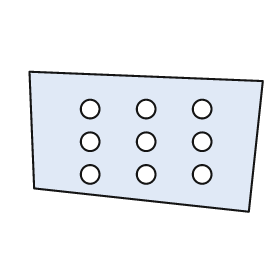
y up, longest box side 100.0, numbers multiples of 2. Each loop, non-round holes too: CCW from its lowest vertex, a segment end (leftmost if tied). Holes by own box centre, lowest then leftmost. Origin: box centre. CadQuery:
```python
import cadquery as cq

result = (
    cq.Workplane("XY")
    .moveTo(44.0, -30.0)
    .lineTo(50.0, 26.0)
    .lineTo(-50.0, 30.0)
    .lineTo(-48.0, -20.0)
    .close()
    .moveTo(-24.0, -14.0)
    .circle(4.0)
    .moveTo(0.0, -14.0)
    .circle(4.0)
    .moveTo(24.0, -14.0)
    .circle(4.0)
    .moveTo(-24.0, 0.0)
    .circle(4.0)
    .moveTo(0.0, 0.0)
    .circle(4.0)
    .moveTo(24.0, 0.0)
    .circle(4.0)
    .moveTo(-24.0, 14.0)
    .circle(4.0)
    .moveTo(0.0, 14.0)
    .circle(4.0)
    .moveTo(24.0, 14.0)
    .circle(4.0)
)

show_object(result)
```